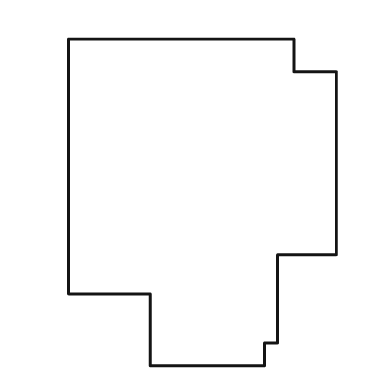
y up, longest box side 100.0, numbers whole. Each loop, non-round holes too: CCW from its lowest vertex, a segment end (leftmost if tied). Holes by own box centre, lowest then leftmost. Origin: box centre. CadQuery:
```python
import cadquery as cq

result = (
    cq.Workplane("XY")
    .moveTo(-16.0, -50.0)
    .lineTo(19.0, -50.0)
    .lineTo(19.0, -43.0)
    .lineTo(23.0, -43.0)
    .lineTo(23.0, -16.0)
    .lineTo(41.0, -16.0)
    .lineTo(41.0, 40.0)
    .lineTo(28.0, 40.0)
    .lineTo(28.0, 50.0)
    .lineTo(-41.0, 50.0)
    .lineTo(-41.0, -28.0)
    .lineTo(-16.0, -28.0)
    .close()
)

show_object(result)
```